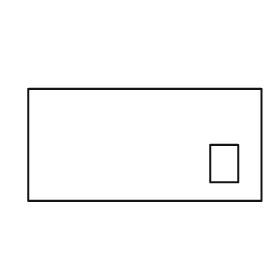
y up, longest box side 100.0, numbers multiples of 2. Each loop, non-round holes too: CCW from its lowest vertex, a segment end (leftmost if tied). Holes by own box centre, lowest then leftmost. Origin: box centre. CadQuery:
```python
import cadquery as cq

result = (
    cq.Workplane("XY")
    .moveTo(-50.0, -24.0)
    .lineTo(50.0, -24.0)
    .lineTo(50.0, 24.0)
    .lineTo(-50.0, 24.0)
    .close()
    .moveTo(28.0, -16.0)
    .lineTo(40.0, -16.0)
    .lineTo(40.0, 0.0)
    .lineTo(28.0, 0.0)
    .close()
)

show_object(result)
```